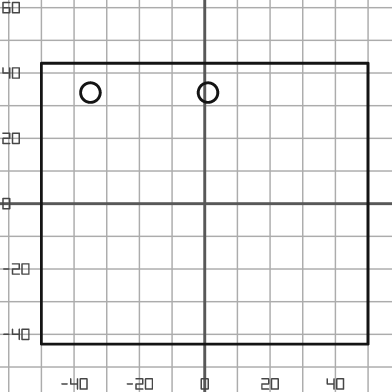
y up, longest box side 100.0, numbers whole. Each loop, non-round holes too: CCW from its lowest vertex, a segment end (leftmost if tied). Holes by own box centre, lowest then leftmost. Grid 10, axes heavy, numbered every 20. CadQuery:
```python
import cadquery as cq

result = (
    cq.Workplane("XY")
    .moveTo(-50.0, -43.0)
    .lineTo(50.0, -43.0)
    .lineTo(50.0, 43.0)
    .lineTo(-50.0, 43.0)
    .close()
    .moveTo(-35.0, 34.0)
    .circle(3.0)
    .moveTo(1.0, 34.0)
    .circle(3.0)
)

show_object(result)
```